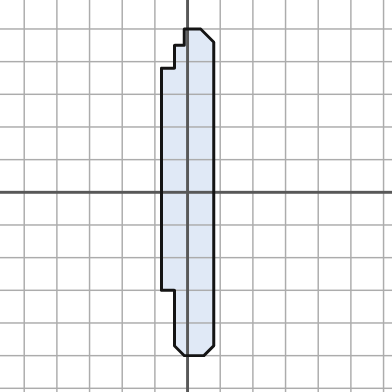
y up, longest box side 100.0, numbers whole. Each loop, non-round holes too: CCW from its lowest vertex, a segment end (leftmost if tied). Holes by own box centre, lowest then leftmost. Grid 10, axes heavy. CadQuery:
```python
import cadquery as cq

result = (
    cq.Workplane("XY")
    .moveTo(-1.0, -50.0)
    .lineTo(5.0, -50.0)
    .lineTo(8.0, -47.0)
    .lineTo(8.0, 46.0)
    .lineTo(4.0, 50.0)
    .lineTo(-1.0, 50.0)
    .lineTo(-1.0, 45.0)
    .lineTo(-4.0, 45.0)
    .lineTo(-4.0, 38.0)
    .lineTo(-8.0, 38.0)
    .lineTo(-8.0, -30.0)
    .lineTo(-4.0, -30.0)
    .lineTo(-4.0, -47.0)
    .close()
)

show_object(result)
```